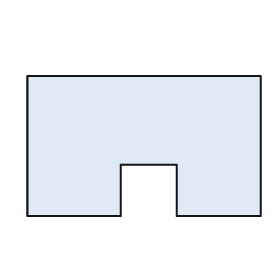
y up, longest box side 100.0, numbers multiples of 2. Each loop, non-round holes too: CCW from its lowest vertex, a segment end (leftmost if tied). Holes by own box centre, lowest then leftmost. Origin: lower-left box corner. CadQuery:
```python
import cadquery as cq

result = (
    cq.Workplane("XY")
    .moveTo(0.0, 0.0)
    .lineTo(40.0, 0.0)
    .lineTo(40.0, 22.0)
    .lineTo(64.0, 22.0)
    .lineTo(64.0, 0.0)
    .lineTo(100.0, 0.0)
    .lineTo(100.0, 60.0)
    .lineTo(0.0, 60.0)
    .close()
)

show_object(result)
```